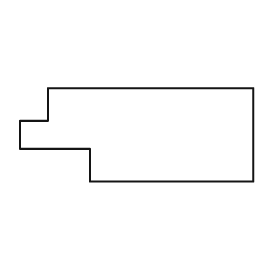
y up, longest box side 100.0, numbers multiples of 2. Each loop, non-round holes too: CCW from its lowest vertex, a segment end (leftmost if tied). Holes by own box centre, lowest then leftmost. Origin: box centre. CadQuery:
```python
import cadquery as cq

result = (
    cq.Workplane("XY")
    .moveTo(-20.0, -20.0)
    .lineTo(50.0, -20.0)
    .lineTo(50.0, 20.0)
    .lineTo(-38.0, 20.0)
    .lineTo(-38.0, 6.0)
    .lineTo(-50.0, 6.0)
    .lineTo(-50.0, -6.0)
    .lineTo(-20.0, -6.0)
    .close()
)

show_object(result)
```